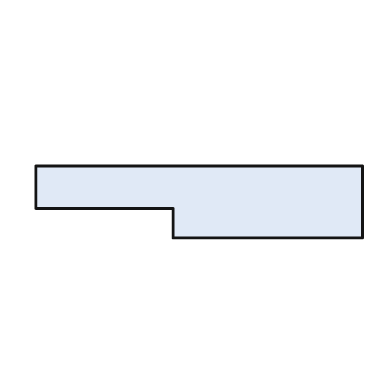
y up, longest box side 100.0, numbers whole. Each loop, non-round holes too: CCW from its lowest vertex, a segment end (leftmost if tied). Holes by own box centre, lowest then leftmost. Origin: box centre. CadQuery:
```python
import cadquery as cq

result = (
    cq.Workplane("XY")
    .moveTo(-8.0, -11.0)
    .lineTo(50.0, -11.0)
    .lineTo(50.0, 11.0)
    .lineTo(-50.0, 11.0)
    .lineTo(-50.0, -2.0)
    .lineTo(-8.0, -2.0)
    .close()
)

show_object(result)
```